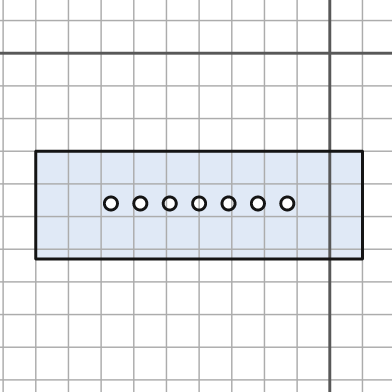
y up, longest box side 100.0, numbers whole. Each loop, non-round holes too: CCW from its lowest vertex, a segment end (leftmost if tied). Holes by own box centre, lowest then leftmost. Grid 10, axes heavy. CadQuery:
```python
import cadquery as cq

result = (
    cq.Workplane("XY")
    .moveTo(-90.0, -63.0)
    .lineTo(10.0, -63.0)
    .lineTo(10.0, -30.0)
    .lineTo(-90.0, -30.0)
    .close()
    .moveTo(-67.0, -46.0)
    .circle(2.0)
    .moveTo(-58.0, -46.0)
    .circle(2.0)
    .moveTo(-49.0, -46.0)
    .circle(2.0)
    .moveTo(-40.0, -46.0)
    .circle(2.0)
    .moveTo(-31.0, -46.0)
    .circle(2.0)
    .moveTo(-22.0, -46.0)
    .circle(2.0)
    .moveTo(-13.0, -46.0)
    .circle(2.0)
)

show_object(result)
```